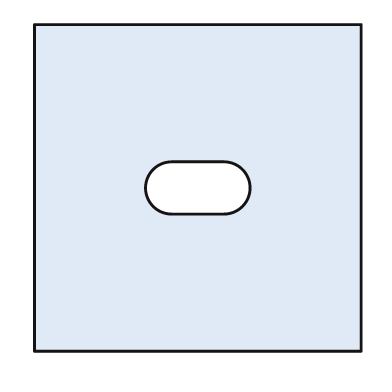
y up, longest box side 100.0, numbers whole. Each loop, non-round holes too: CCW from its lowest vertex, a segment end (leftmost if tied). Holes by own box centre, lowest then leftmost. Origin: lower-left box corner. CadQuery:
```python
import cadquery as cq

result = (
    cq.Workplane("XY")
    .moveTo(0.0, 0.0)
    .lineTo(100.0, 0.0)
    .lineTo(100.0, 100.0)
    .lineTo(0.0, 100.0)
    .close()
    .moveTo(42.0, 42.0)
    .lineTo(58.0, 42.0)
    .threePointArc((66.0, 50.0), (58.0, 58.0))
    .lineTo(42.0, 58.0)
    .threePointArc((34.0, 50.0), (42.0, 42.0))
    .close()
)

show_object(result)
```